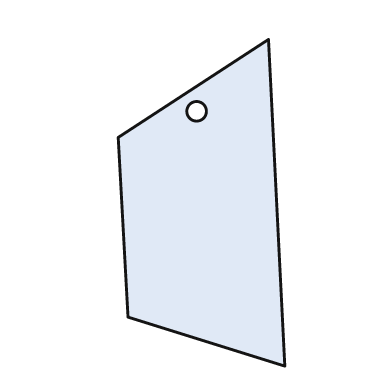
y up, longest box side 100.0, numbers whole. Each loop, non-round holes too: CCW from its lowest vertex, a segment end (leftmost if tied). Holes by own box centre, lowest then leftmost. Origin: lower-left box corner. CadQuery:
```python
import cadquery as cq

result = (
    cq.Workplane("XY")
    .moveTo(51.0, 0.0)
    .lineTo(46.0, 100.0)
    .lineTo(0.0, 70.0)
    .lineTo(3.0, 15.0)
    .close()
    .moveTo(24.0, 78.0)
    .circle(3.0)
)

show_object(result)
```